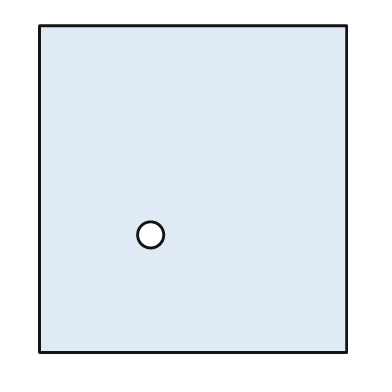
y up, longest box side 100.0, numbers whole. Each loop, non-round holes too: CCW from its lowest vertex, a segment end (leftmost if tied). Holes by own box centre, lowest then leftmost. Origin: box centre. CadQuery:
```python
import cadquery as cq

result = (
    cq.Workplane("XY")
    .moveTo(-47.0, -50.0)
    .lineTo(47.0, -50.0)
    .lineTo(47.0, 50.0)
    .lineTo(-47.0, 50.0)
    .close()
    .moveTo(-13.0, -14.0)
    .circle(4.0)
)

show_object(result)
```